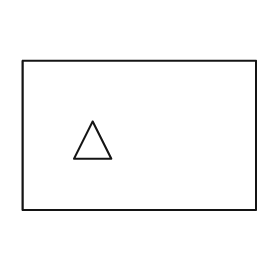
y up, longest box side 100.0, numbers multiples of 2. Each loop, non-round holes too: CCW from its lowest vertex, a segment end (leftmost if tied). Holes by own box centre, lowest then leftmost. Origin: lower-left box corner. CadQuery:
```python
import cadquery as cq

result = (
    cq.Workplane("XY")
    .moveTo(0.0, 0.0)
    .lineTo(100.0, 0.0)
    .lineTo(100.0, 64.0)
    .lineTo(0.0, 64.0)
    .close()
    .moveTo(22.0, 22.0)
    .lineTo(38.0, 22.0)
    .lineTo(30.0, 38.0)
    .close()
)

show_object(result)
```